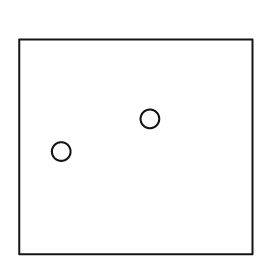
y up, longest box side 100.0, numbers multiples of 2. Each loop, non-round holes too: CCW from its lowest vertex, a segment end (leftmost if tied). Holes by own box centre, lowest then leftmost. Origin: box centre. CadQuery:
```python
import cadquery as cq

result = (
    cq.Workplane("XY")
    .moveTo(-50.0, -46.0)
    .lineTo(50.0, -46.0)
    .lineTo(50.0, 46.0)
    .lineTo(-50.0, 46.0)
    .close()
    .moveTo(-32.0, -2.0)
    .circle(4.0)
    .moveTo(6.0, 12.0)
    .circle(4.0)
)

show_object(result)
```